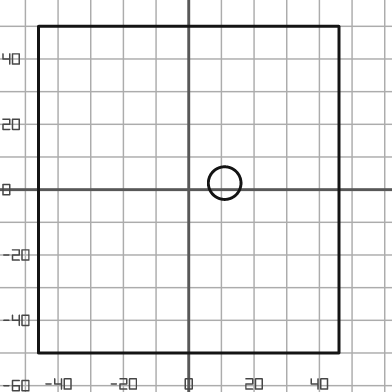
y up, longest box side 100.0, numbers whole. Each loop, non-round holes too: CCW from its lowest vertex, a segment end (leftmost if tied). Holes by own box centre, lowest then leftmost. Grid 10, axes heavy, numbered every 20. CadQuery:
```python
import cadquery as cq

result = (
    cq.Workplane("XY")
    .moveTo(-46.0, -50.0)
    .lineTo(46.0, -50.0)
    .lineTo(46.0, 50.0)
    .lineTo(-46.0, 50.0)
    .close()
    .moveTo(11.0, 2.0)
    .circle(5.0)
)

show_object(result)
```